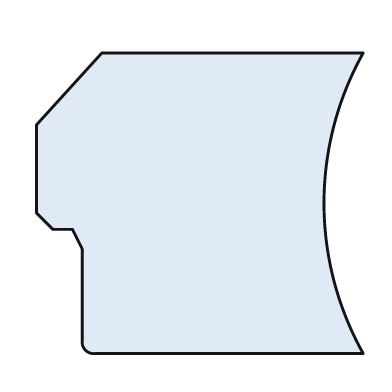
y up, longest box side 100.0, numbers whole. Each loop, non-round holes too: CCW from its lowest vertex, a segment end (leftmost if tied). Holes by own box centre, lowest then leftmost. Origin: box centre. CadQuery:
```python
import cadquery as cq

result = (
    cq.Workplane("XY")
    .moveTo(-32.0, -46.0)
    .lineTo(50.0, -46.0)
    .threePointArc((38.0, 0.0), (50.0, 46.0))
    .lineTo(-30.0, 46.0)
    .lineTo(-50.0, 24.0)
    .lineTo(-50.0, -3.0)
    .lineTo(-45.0, -8.0)
    .lineTo(-39.0, -8.0)
    .lineTo(-36.0, -14.0)
    .lineTo(-36.0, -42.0)
    .threePointArc((-35.0, -45.0), (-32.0, -46.0))
    .close()
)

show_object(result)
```